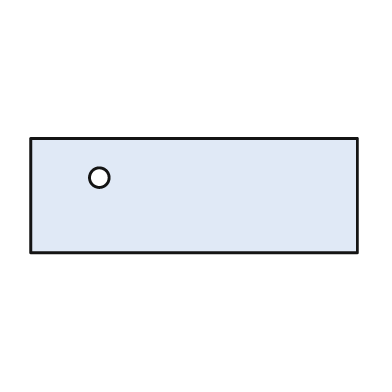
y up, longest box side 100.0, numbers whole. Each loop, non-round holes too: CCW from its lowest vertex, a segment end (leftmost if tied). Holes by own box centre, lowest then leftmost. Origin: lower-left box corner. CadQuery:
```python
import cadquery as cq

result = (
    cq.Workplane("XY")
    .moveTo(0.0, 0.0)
    .lineTo(100.0, 0.0)
    .lineTo(100.0, 35.0)
    .lineTo(0.0, 35.0)
    .close()
    .moveTo(21.0, 23.0)
    .circle(3.0)
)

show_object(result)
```